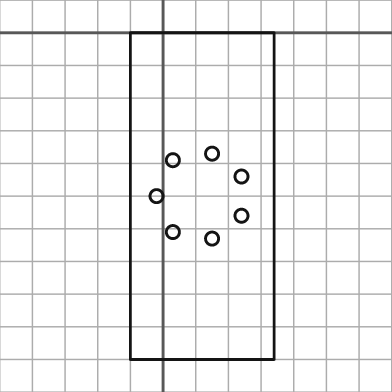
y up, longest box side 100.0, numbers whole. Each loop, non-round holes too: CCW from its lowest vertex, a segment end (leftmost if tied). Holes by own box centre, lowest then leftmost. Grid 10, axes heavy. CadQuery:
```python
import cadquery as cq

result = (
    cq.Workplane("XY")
    .moveTo(-10.0, -100.0)
    .lineTo(34.0, -100.0)
    .lineTo(34.0, 0.0)
    .lineTo(-10.0, 0.0)
    .close()
    .moveTo(15.0, -63.0)
    .circle(2.0)
    .moveTo(3.0, -61.0)
    .circle(2.0)
    .moveTo(24.0, -56.0)
    .circle(2.0)
    .moveTo(-2.0, -50.0)
    .circle(2.0)
    .moveTo(24.0, -44.0)
    .circle(2.0)
    .moveTo(3.0, -39.0)
    .circle(2.0)
    .moveTo(15.0, -37.0)
    .circle(2.0)
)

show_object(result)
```